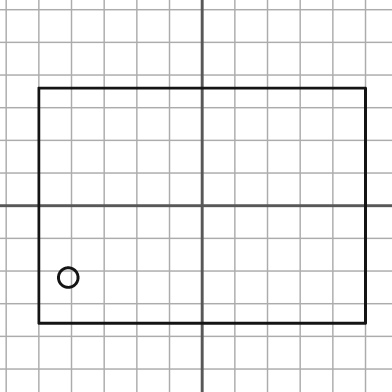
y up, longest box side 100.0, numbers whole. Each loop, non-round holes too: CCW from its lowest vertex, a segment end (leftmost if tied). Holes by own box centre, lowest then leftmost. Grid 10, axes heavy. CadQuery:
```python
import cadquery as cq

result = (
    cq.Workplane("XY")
    .moveTo(-50.0, -36.0)
    .lineTo(50.0, -36.0)
    .lineTo(50.0, 36.0)
    .lineTo(-50.0, 36.0)
    .close()
    .moveTo(-41.0, -22.0)
    .circle(3.0)
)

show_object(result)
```